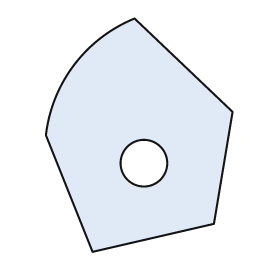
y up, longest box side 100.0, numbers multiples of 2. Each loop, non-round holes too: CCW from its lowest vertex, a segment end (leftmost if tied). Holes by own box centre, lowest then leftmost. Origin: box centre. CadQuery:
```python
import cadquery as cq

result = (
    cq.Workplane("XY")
    .moveTo(-20.0, -50.0)
    .lineTo(32.0, -38.0)
    .lineTo(40.0, 10.0)
    .lineTo(-2.0, 50.0)
    .threePointArc((-28.0, 30.0), (-40.0, 0.0))
    .close()
    .moveTo(2.0, -12.0)
    .circle(10.0)
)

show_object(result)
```